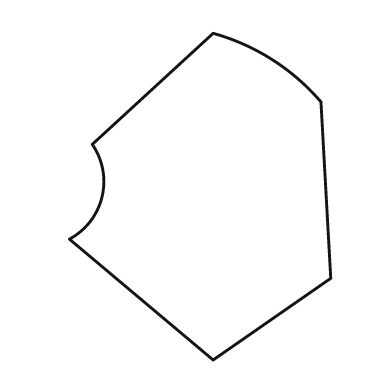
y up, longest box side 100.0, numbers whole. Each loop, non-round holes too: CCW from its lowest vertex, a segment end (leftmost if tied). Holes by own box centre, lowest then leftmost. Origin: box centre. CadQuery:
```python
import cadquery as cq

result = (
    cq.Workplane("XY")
    .moveTo(4.0, -50.0)
    .lineTo(40.0, -25.0)
    .lineTo(37.0, 29.0)
    .threePointArc((22.0, 42.0), (4.0, 50.0))
    .lineTo(-33.0, 16.0)
    .threePointArc((-30.0, 0.0), (-40.0, -13.0))
    .close()
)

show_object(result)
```